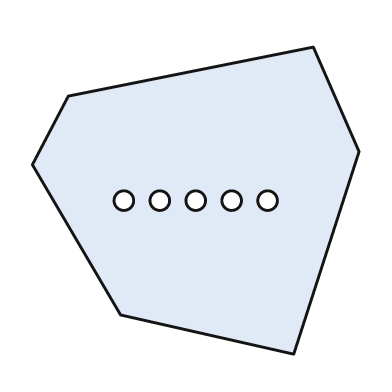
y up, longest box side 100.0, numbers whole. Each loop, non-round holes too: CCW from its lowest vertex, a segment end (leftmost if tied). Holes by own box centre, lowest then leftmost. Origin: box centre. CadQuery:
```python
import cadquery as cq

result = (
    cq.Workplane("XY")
    .moveTo(30.0, -47.0)
    .lineTo(50.0, 15.0)
    .lineTo(36.0, 47.0)
    .lineTo(-39.0, 32.0)
    .lineTo(-50.0, 11.0)
    .lineTo(-23.0, -35.0)
    .close()
    .moveTo(-22.0, 0.0)
    .circle(3.0)
    .moveTo(-11.0, 0.0)
    .circle(3.0)
    .moveTo(0.0, 0.0)
    .circle(3.0)
    .moveTo(11.0, 0.0)
    .circle(3.0)
    .moveTo(22.0, 0.0)
    .circle(3.0)
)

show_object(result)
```